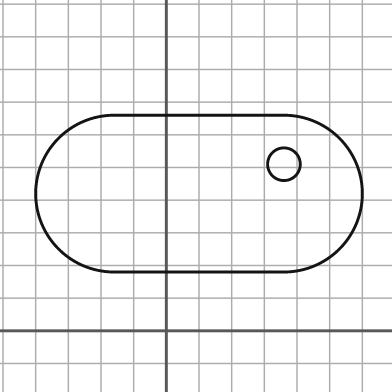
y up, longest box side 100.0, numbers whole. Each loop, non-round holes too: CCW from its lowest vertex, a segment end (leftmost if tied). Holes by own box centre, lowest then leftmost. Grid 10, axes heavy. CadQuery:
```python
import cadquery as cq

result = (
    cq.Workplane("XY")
    .moveTo(-16.0, 18.0)
    .lineTo(36.0, 18.0)
    .threePointArc((60.0, 42.0), (36.0, 66.0))
    .lineTo(-16.0, 66.0)
    .threePointArc((-40.0, 42.0), (-16.0, 18.0))
    .close()
    .moveTo(36.0, 51.0)
    .circle(5.0)
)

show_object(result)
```